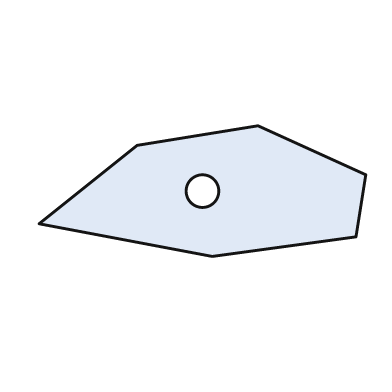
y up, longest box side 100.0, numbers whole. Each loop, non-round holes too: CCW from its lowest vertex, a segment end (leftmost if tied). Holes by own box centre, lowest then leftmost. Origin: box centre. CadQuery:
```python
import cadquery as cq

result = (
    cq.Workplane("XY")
    .moveTo(3.0, -20.0)
    .lineTo(47.0, -14.0)
    .lineTo(50.0, 5.0)
    .lineTo(17.0, 20.0)
    .lineTo(-20.0, 14.0)
    .lineTo(-50.0, -10.0)
    .close()
    .moveTo(0.0, 0.0)
    .circle(5.0)
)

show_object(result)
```